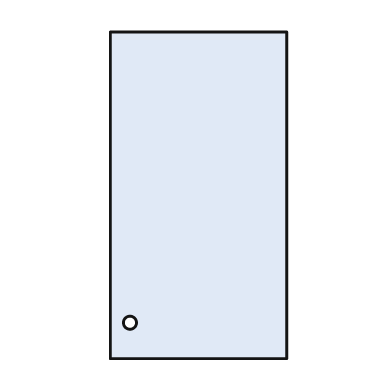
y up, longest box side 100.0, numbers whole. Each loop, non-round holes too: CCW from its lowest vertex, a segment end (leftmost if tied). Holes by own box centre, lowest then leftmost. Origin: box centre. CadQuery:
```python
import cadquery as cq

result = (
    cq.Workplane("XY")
    .moveTo(-27.0, -50.0)
    .lineTo(27.0, -50.0)
    .lineTo(27.0, 50.0)
    .lineTo(-27.0, 50.0)
    .close()
    .moveTo(-21.0, -39.0)
    .circle(2.0)
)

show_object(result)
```